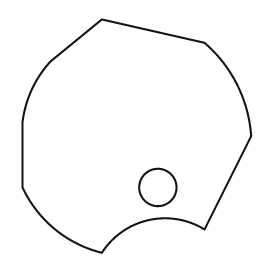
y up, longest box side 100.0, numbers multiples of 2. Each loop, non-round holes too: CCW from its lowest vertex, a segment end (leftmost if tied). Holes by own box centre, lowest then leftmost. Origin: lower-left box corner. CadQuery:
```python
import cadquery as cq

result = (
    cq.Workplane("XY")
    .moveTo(34.0, 0.0)
    .threePointArc((54.0, 14.0), (78.0, 10.0))
    .lineTo(98.0, 50.0)
    .threePointArc((92.0, 72.0), (78.0, 90.0))
    .lineTo(34.0, 100.0)
    .lineTo(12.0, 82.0)
    .threePointArc((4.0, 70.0), (0.0, 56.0))
    .lineTo(0.0, 28.0)
    .threePointArc((14.0, 10.0), (34.0, 0.0))
    .close()
    .moveTo(58.0, 28.0)
    .circle(8.0)
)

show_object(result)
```